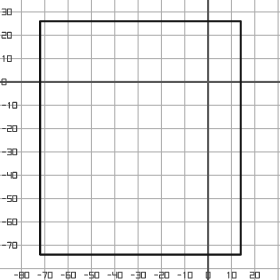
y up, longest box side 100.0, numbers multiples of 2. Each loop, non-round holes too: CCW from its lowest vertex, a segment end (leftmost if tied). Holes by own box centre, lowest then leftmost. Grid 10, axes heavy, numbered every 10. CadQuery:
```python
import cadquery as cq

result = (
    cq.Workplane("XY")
    .moveTo(-72.0, -74.0)
    .lineTo(14.0, -74.0)
    .lineTo(14.0, 26.0)
    .lineTo(-72.0, 26.0)
    .close()
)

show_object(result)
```